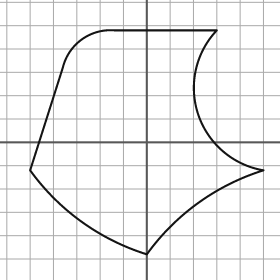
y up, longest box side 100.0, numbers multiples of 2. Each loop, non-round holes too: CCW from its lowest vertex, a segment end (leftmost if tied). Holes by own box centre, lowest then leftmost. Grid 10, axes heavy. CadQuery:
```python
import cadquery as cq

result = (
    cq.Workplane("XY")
    .moveTo(0.0, -48.0)
    .threePointArc((22.0, -26.0), (50.0, -12.0))
    .threePointArc((22.0, 12.0), (30.0, 48.0))
    .lineTo(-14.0, 48.0)
    .threePointArc((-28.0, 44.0), (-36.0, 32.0))
    .lineTo(-50.0, -12.0)
    .threePointArc((-28.0, -34.0), (0.0, -48.0))
    .close()
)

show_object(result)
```